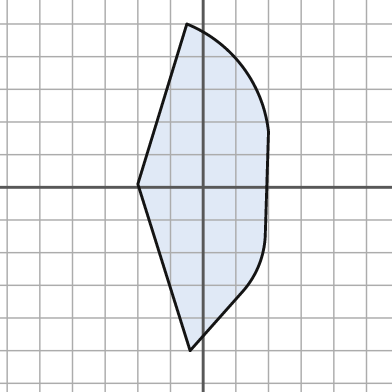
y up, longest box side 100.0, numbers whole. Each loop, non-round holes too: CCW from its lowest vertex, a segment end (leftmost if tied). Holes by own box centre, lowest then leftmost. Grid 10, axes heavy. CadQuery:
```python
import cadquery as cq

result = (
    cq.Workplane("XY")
    .moveTo(-4.0, -50.0)
    .lineTo(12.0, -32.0)
    .threePointArc((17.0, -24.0), (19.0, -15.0))
    .lineTo(20.0, 17.0)
    .threePointArc((12.0, 37.0), (-5.0, 50.0))
    .lineTo(-20.0, 1.0)
    .close()
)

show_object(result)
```